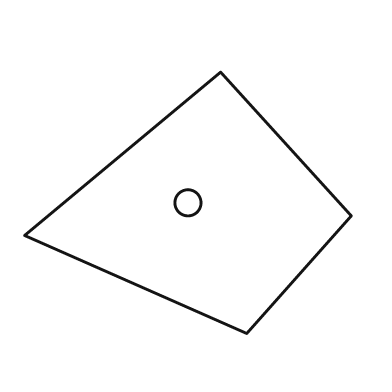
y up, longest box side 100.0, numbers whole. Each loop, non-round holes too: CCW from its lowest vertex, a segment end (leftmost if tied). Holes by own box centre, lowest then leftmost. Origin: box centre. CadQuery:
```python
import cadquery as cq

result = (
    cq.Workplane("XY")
    .moveTo(18.0, -40.0)
    .lineTo(50.0, -4.0)
    .lineTo(10.0, 40.0)
    .lineTo(-50.0, -10.0)
    .close()
    .moveTo(0.0, 0.0)
    .circle(4.0)
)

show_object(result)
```